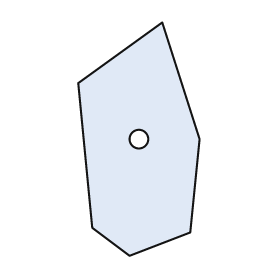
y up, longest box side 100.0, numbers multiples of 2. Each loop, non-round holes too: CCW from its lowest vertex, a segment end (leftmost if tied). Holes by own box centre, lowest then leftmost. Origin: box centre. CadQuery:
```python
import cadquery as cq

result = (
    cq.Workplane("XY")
    .moveTo(-4.0, -50.0)
    .lineTo(22.0, -40.0)
    .lineTo(26.0, 0.0)
    .lineTo(10.0, 50.0)
    .lineTo(-26.0, 24.0)
    .lineTo(-20.0, -38.0)
    .close()
    .moveTo(0.0, 0.0)
    .circle(4.0)
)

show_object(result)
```